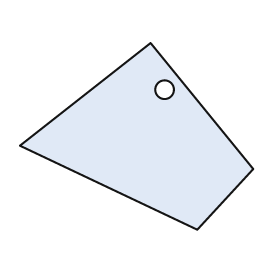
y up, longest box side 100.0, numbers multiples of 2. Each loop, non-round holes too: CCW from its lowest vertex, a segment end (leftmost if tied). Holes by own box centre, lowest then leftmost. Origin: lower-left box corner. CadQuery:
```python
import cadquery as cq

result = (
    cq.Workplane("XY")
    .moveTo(76.0, 0.0)
    .lineTo(100.0, 26.0)
    .lineTo(56.0, 80.0)
    .lineTo(0.0, 36.0)
    .close()
    .moveTo(62.0, 60.0)
    .circle(4.0)
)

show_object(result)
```